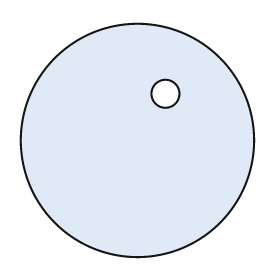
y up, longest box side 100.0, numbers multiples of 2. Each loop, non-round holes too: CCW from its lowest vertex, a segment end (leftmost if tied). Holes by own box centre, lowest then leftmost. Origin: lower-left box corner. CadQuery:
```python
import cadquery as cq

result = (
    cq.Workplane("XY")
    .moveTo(50.0, 50.0)
    .circle(50.0)
    .moveTo(62.0, 70.0)
    .circle(6.0)
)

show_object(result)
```